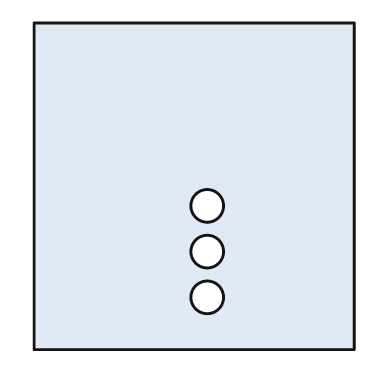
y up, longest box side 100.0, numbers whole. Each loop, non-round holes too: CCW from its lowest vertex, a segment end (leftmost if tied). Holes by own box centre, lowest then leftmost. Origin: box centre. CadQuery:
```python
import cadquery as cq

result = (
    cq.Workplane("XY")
    .moveTo(-49.0, -50.0)
    .lineTo(49.0, -50.0)
    .lineTo(49.0, 50.0)
    .lineTo(-49.0, 50.0)
    .close()
    .moveTo(4.0, -34.0)
    .circle(5.0)
    .moveTo(4.0, -20.0)
    .circle(5.0)
    .moveTo(4.0, -6.0)
    .circle(5.0)
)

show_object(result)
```